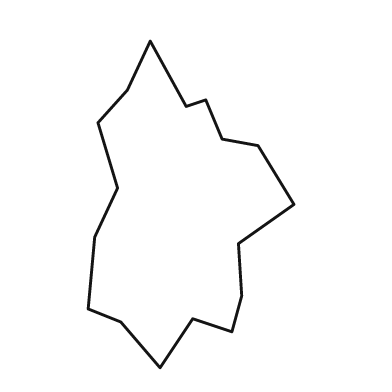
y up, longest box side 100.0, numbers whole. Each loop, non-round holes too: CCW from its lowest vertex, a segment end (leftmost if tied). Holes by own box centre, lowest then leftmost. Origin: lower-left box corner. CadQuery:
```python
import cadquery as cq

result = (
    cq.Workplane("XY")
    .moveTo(22.0, 0.0)
    .lineTo(32.0, 15.0)
    .lineTo(44.0, 11.0)
    .lineTo(47.0, 22.0)
    .lineTo(46.0, 38.0)
    .lineTo(63.0, 50.0)
    .lineTo(52.0, 68.0)
    .lineTo(41.0, 70.0)
    .lineTo(36.0, 82.0)
    .lineTo(30.0, 80.0)
    .lineTo(19.0, 100.0)
    .lineTo(12.0, 85.0)
    .lineTo(3.0, 75.0)
    .lineTo(9.0, 55.0)
    .lineTo(2.0, 40.0)
    .lineTo(0.0, 18.0)
    .lineTo(10.0, 14.0)
    .close()
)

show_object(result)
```